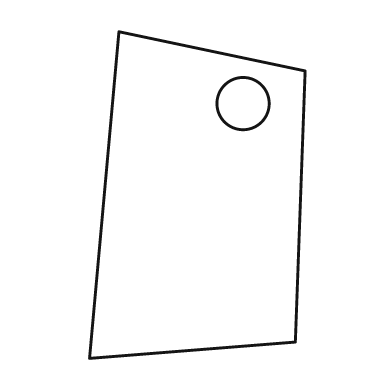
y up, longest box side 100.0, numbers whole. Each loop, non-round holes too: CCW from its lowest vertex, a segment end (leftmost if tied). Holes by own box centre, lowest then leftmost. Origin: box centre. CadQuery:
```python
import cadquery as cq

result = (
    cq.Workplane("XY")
    .moveTo(-33.0, -50.0)
    .lineTo(30.0, -45.0)
    .lineTo(33.0, 38.0)
    .lineTo(-24.0, 50.0)
    .close()
    .moveTo(14.0, 28.0)
    .circle(8.0)
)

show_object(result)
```